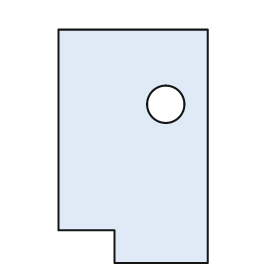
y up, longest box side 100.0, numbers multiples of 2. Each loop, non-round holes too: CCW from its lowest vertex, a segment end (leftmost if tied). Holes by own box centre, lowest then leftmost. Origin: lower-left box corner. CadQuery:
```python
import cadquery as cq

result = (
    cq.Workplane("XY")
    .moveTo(24.0, 0.0)
    .lineTo(64.0, 0.0)
    .lineTo(64.0, 100.0)
    .lineTo(0.0, 100.0)
    .lineTo(0.0, 14.0)
    .lineTo(24.0, 14.0)
    .close()
    .moveTo(46.0, 68.0)
    .circle(8.0)
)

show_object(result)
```